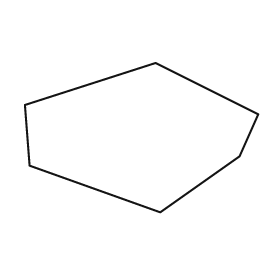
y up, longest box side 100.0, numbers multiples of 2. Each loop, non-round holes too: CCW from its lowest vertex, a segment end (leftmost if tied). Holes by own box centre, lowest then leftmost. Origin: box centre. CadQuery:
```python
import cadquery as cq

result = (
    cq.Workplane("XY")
    .moveTo(8.0, -32.0)
    .lineTo(42.0, -8.0)
    .lineTo(50.0, 10.0)
    .lineTo(6.0, 32.0)
    .lineTo(-50.0, 14.0)
    .lineTo(-48.0, -12.0)
    .close()
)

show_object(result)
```